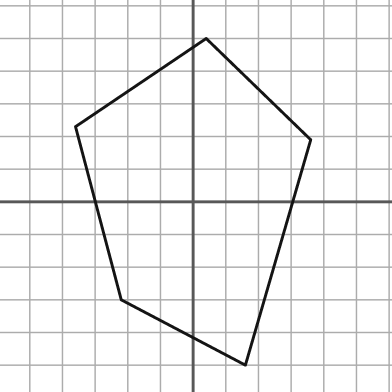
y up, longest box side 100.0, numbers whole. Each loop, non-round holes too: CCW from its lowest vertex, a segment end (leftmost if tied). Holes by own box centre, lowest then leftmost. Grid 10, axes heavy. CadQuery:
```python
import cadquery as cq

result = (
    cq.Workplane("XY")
    .moveTo(16.0, -50.0)
    .lineTo(36.0, 19.0)
    .lineTo(4.0, 50.0)
    .lineTo(-36.0, 23.0)
    .lineTo(-22.0, -30.0)
    .close()
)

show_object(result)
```